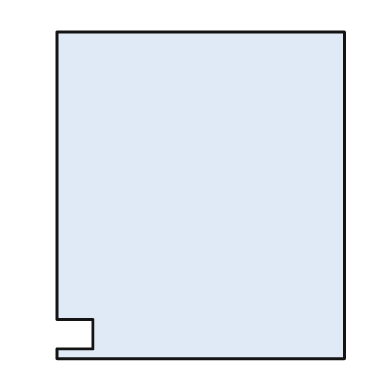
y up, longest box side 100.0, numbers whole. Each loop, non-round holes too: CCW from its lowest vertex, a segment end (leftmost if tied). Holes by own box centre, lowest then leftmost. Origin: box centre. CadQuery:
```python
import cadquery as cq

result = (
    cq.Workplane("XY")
    .moveTo(-44.0, -50.0)
    .lineTo(44.0, -50.0)
    .lineTo(44.0, 50.0)
    .lineTo(-44.0, 50.0)
    .lineTo(-44.0, -38.0)
    .lineTo(-33.0, -38.0)
    .lineTo(-33.0, -47.0)
    .lineTo(-44.0, -47.0)
    .close()
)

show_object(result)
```